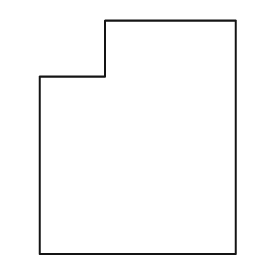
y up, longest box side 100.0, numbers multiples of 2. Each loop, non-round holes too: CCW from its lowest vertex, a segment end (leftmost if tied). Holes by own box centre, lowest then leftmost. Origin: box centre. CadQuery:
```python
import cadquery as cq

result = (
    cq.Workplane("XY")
    .moveTo(-42.0, -50.0)
    .lineTo(42.0, -50.0)
    .lineTo(42.0, 50.0)
    .lineTo(-14.0, 50.0)
    .lineTo(-14.0, 26.0)
    .lineTo(-42.0, 26.0)
    .close()
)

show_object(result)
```